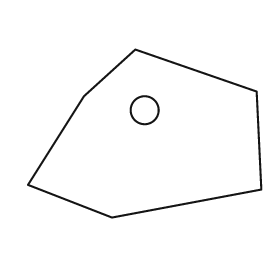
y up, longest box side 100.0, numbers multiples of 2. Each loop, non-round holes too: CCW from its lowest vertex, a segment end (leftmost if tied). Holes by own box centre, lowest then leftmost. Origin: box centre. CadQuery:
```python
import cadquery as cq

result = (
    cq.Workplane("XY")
    .moveTo(-14.0, -36.0)
    .lineTo(50.0, -24.0)
    .lineTo(48.0, 18.0)
    .lineTo(-4.0, 36.0)
    .lineTo(-26.0, 16.0)
    .lineTo(-50.0, -22.0)
    .close()
    .moveTo(0.0, 10.0)
    .circle(6.0)
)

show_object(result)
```